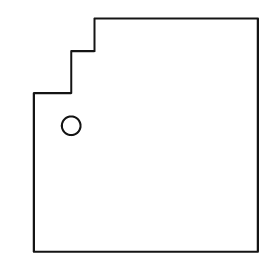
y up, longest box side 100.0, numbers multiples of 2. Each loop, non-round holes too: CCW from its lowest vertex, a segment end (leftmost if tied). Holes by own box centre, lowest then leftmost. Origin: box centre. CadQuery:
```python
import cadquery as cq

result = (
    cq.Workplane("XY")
    .moveTo(-48.0, -50.0)
    .lineTo(48.0, -50.0)
    .lineTo(48.0, 50.0)
    .lineTo(-22.0, 50.0)
    .lineTo(-22.0, 36.0)
    .lineTo(-32.0, 36.0)
    .lineTo(-32.0, 18.0)
    .lineTo(-48.0, 18.0)
    .close()
    .moveTo(-32.0, 4.0)
    .circle(4.0)
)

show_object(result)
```